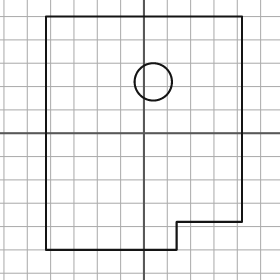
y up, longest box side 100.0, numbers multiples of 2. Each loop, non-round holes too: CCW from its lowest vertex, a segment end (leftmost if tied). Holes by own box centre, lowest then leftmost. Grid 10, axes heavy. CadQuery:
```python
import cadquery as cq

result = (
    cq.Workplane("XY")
    .moveTo(-42.0, -50.0)
    .lineTo(14.0, -50.0)
    .lineTo(14.0, -38.0)
    .lineTo(42.0, -38.0)
    .lineTo(42.0, 50.0)
    .lineTo(-42.0, 50.0)
    .close()
    .moveTo(4.0, 22.0)
    .circle(8.0)
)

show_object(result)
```